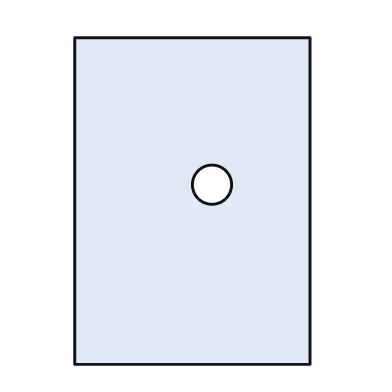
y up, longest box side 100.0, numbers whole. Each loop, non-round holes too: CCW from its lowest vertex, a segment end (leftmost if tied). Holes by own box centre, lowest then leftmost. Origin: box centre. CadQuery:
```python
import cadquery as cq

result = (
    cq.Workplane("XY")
    .moveTo(-36.0, -50.0)
    .lineTo(36.0, -50.0)
    .lineTo(36.0, 50.0)
    .lineTo(-36.0, 50.0)
    .close()
    .moveTo(6.0, 5.0)
    .circle(6.0)
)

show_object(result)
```